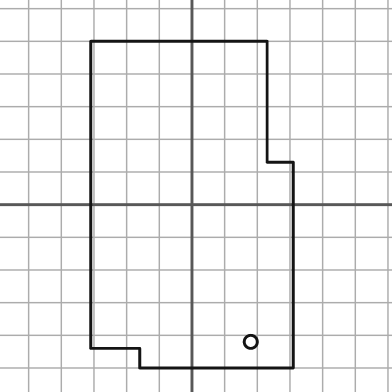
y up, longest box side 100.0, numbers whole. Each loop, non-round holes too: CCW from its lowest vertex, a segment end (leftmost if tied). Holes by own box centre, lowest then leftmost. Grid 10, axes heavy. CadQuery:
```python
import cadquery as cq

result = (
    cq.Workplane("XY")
    .moveTo(-16.0, -50.0)
    .lineTo(31.0, -50.0)
    .lineTo(31.0, 13.0)
    .lineTo(23.0, 13.0)
    .lineTo(23.0, 50.0)
    .lineTo(-31.0, 50.0)
    .lineTo(-31.0, -44.0)
    .lineTo(-16.0, -44.0)
    .close()
    .moveTo(18.0, -42.0)
    .circle(2.0)
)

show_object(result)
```